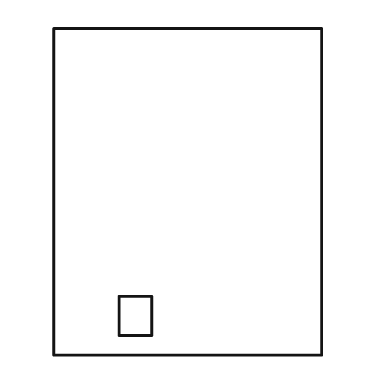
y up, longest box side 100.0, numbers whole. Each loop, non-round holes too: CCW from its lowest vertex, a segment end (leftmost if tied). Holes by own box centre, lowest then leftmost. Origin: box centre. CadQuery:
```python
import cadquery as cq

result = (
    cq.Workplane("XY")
    .moveTo(-41.0, -50.0)
    .lineTo(41.0, -50.0)
    .lineTo(41.0, 50.0)
    .lineTo(-41.0, 50.0)
    .close()
    .moveTo(-21.0, -44.0)
    .lineTo(-11.0, -44.0)
    .lineTo(-11.0, -32.0)
    .lineTo(-21.0, -32.0)
    .close()
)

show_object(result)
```